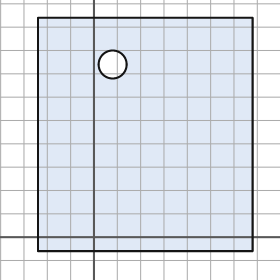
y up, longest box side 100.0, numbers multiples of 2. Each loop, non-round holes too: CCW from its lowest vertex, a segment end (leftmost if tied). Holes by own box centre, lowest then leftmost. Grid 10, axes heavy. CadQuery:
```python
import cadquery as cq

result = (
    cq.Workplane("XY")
    .moveTo(-24.0, -6.0)
    .lineTo(68.0, -6.0)
    .lineTo(68.0, 94.0)
    .lineTo(-24.0, 94.0)
    .close()
    .moveTo(8.0, 74.0)
    .circle(6.0)
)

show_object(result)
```